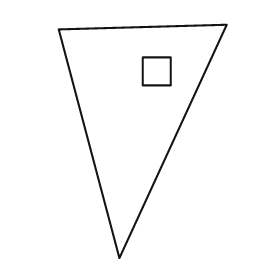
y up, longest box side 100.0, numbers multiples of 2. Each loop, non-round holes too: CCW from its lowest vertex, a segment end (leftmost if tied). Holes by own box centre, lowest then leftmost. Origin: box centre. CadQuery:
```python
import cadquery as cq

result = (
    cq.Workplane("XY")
    .moveTo(-10.0, -50.0)
    .lineTo(36.0, 50.0)
    .lineTo(-36.0, 48.0)
    .close()
    .moveTo(0.0, 24.0)
    .lineTo(12.0, 24.0)
    .lineTo(12.0, 36.0)
    .lineTo(0.0, 36.0)
    .close()
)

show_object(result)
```